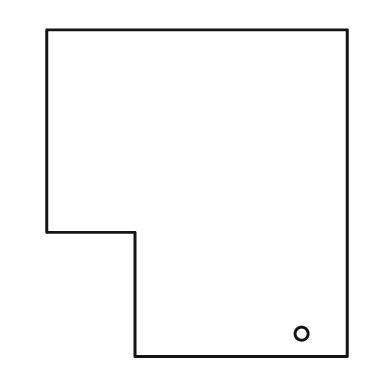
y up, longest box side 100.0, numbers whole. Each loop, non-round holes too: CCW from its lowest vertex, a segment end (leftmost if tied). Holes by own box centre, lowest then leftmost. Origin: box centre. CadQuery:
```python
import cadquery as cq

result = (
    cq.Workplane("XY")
    .moveTo(-19.0, -50.0)
    .lineTo(46.0, -50.0)
    .lineTo(46.0, 50.0)
    .lineTo(-46.0, 50.0)
    .lineTo(-46.0, -12.0)
    .lineTo(-19.0, -12.0)
    .close()
    .moveTo(32.0, -43.0)
    .circle(2.0)
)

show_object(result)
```